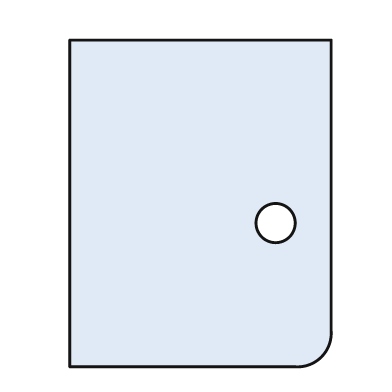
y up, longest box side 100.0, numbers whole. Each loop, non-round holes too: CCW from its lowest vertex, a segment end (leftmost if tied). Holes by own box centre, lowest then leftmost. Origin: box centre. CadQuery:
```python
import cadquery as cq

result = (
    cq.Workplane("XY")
    .moveTo(-40.0, -50.0)
    .lineTo(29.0, -50.0)
    .threePointArc((37.0, -47.0), (40.0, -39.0))
    .lineTo(40.0, 50.0)
    .lineTo(-40.0, 50.0)
    .close()
    .moveTo(23.0, -6.0)
    .circle(6.0)
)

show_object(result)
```